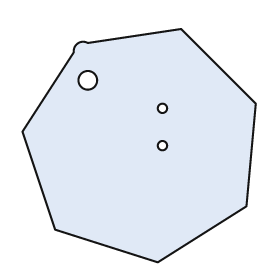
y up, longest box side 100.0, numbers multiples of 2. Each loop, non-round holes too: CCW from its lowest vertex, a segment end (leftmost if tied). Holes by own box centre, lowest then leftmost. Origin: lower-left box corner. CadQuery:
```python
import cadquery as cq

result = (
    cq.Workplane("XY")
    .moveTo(58.0, 0.0)
    .lineTo(96.0, 24.0)
    .lineTo(100.0, 68.0)
    .lineTo(68.0, 100.0)
    .lineTo(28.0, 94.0)
    .threePointArc((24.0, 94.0), (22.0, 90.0))
    .lineTo(0.0, 56.0)
    .lineTo(14.0, 14.0)
    .close()
    .moveTo(60.0, 50.0)
    .circle(2.0)
    .moveTo(60.0, 66.0)
    .circle(2.0)
    .moveTo(28.0, 78.0)
    .circle(4.0)
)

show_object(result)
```